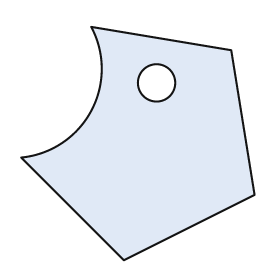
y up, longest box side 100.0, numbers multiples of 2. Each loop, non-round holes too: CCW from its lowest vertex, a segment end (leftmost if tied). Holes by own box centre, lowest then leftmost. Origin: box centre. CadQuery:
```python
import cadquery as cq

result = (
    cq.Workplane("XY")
    .moveTo(-6.0, -50.0)
    .lineTo(50.0, -22.0)
    .lineTo(40.0, 40.0)
    .lineTo(-20.0, 50.0)
    .threePointArc((-20.0, 14.0), (-50.0, -6.0))
    .close()
    .moveTo(8.0, 26.0)
    .circle(8.0)
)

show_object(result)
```